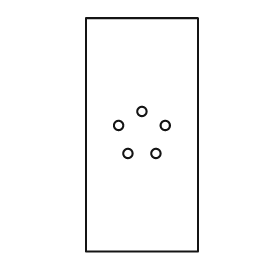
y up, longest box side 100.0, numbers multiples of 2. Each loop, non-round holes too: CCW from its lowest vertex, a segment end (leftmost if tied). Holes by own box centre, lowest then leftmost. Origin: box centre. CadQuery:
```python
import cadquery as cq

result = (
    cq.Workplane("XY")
    .moveTo(-24.0, -50.0)
    .lineTo(24.0, -50.0)
    .lineTo(24.0, 50.0)
    .lineTo(-24.0, 50.0)
    .close()
    .moveTo(-6.0, -8.0)
    .circle(2.0)
    .moveTo(6.0, -8.0)
    .circle(2.0)
    .moveTo(-10.0, 4.0)
    .circle(2.0)
    .moveTo(10.0, 4.0)
    .circle(2.0)
    .moveTo(0.0, 10.0)
    .circle(2.0)
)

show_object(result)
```